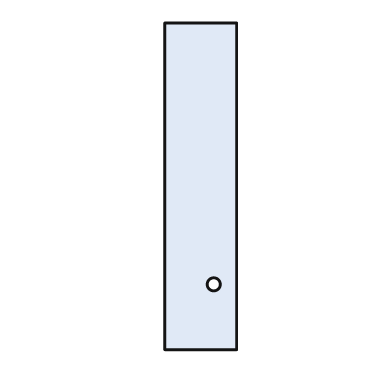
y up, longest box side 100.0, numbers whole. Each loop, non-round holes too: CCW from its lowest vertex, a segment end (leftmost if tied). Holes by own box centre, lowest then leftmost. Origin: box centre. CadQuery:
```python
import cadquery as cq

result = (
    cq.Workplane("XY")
    .moveTo(-11.0, -50.0)
    .lineTo(11.0, -50.0)
    .lineTo(11.0, 50.0)
    .lineTo(-11.0, 50.0)
    .close()
    .moveTo(4.0, -30.0)
    .circle(2.0)
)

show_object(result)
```